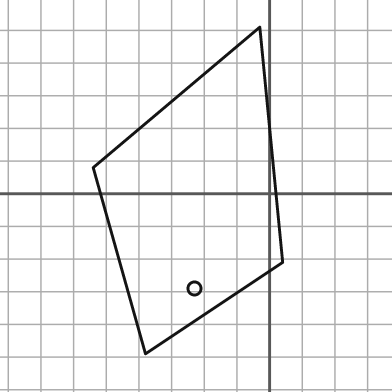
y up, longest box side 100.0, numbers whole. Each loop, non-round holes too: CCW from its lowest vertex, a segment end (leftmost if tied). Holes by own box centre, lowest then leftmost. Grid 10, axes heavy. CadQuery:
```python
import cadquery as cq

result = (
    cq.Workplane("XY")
    .moveTo(-38.0, -49.0)
    .lineTo(4.0, -21.0)
    .lineTo(-3.0, 51.0)
    .lineTo(-54.0, 8.0)
    .close()
    .moveTo(-23.0, -29.0)
    .circle(2.0)
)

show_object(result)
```